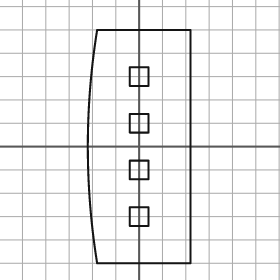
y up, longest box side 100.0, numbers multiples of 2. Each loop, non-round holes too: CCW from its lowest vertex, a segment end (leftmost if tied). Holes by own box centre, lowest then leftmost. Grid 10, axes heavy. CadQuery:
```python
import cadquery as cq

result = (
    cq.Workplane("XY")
    .moveTo(-18.0, -50.0)
    .lineTo(22.0, -50.0)
    .lineTo(22.0, 50.0)
    .lineTo(-18.0, 50.0)
    .threePointArc((-22.0, 0.0), (-18.0, -50.0))
    .close()
    .moveTo(-4.0, -34.0)
    .lineTo(4.0, -34.0)
    .lineTo(4.0, -26.0)
    .lineTo(-4.0, -26.0)
    .close()
    .moveTo(-4.0, -14.0)
    .lineTo(4.0, -14.0)
    .lineTo(4.0, -6.0)
    .lineTo(-4.0, -6.0)
    .close()
    .moveTo(-4.0, 6.0)
    .lineTo(4.0, 6.0)
    .lineTo(4.0, 14.0)
    .lineTo(-4.0, 14.0)
    .close()
    .moveTo(-4.0, 26.0)
    .lineTo(4.0, 26.0)
    .lineTo(4.0, 34.0)
    .lineTo(-4.0, 34.0)
    .close()
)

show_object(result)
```